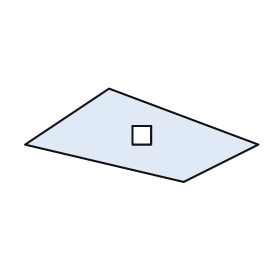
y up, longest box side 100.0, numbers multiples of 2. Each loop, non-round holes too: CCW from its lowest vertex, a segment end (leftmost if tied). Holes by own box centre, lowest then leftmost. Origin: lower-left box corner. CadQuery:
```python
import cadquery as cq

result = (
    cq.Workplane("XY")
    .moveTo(68.0, 0.0)
    .lineTo(100.0, 16.0)
    .lineTo(36.0, 40.0)
    .lineTo(0.0, 16.0)
    .close()
    .moveTo(46.0, 16.0)
    .lineTo(54.0, 16.0)
    .lineTo(54.0, 24.0)
    .lineTo(46.0, 24.0)
    .close()
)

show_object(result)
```